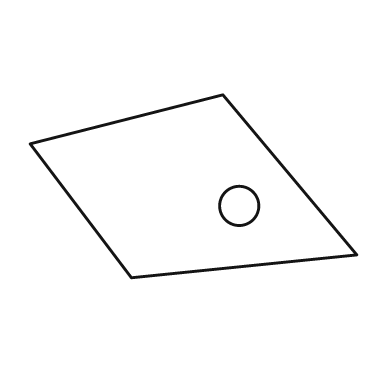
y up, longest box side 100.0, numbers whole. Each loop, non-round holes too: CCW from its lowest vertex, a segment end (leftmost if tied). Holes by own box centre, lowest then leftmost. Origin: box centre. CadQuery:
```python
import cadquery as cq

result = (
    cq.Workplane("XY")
    .moveTo(-19.0, -28.0)
    .lineTo(50.0, -21.0)
    .lineTo(9.0, 28.0)
    .lineTo(-50.0, 13.0)
    .close()
    .moveTo(14.0, -6.0)
    .circle(6.0)
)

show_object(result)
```